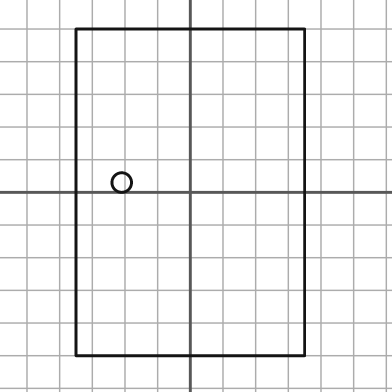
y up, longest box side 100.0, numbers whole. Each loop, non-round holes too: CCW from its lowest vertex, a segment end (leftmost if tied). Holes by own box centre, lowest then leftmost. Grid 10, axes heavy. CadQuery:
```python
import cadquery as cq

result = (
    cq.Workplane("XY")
    .moveTo(-35.0, -50.0)
    .lineTo(35.0, -50.0)
    .lineTo(35.0, 50.0)
    .lineTo(-35.0, 50.0)
    .close()
    .moveTo(-21.0, 3.0)
    .circle(3.0)
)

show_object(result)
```